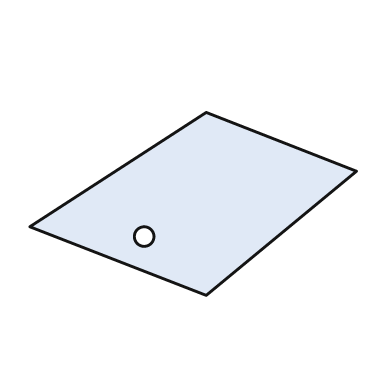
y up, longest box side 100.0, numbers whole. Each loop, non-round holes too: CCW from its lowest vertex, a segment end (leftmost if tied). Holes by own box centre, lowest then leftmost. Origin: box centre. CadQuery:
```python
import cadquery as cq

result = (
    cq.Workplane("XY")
    .moveTo(4.0, -28.0)
    .lineTo(50.0, 10.0)
    .lineTo(4.0, 28.0)
    .lineTo(-50.0, -7.0)
    .close()
    .moveTo(-15.0, -10.0)
    .circle(3.0)
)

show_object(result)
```